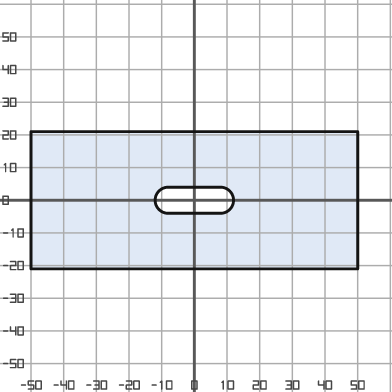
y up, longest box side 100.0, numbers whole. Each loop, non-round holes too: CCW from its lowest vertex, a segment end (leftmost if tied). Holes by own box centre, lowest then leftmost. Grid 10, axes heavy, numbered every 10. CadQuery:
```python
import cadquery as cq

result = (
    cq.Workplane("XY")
    .moveTo(-50.0, -21.0)
    .lineTo(50.0, -21.0)
    .lineTo(50.0, 21.0)
    .lineTo(-50.0, 21.0)
    .close()
    .moveTo(-8.0, -4.0)
    .lineTo(8.0, -4.0)
    .threePointArc((12.0, 0.0), (8.0, 4.0))
    .lineTo(-8.0, 4.0)
    .threePointArc((-12.0, 0.0), (-8.0, -4.0))
    .close()
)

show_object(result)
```